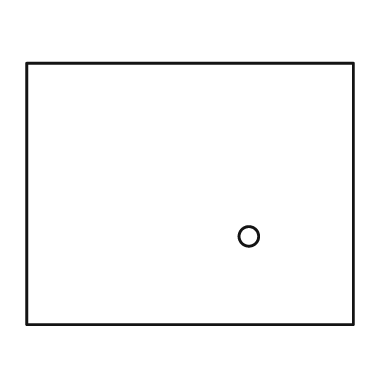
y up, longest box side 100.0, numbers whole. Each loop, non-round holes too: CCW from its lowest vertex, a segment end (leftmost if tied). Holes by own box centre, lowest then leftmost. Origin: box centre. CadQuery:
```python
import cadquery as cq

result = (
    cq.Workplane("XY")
    .moveTo(-50.0, -40.0)
    .lineTo(50.0, -40.0)
    .lineTo(50.0, 40.0)
    .lineTo(-50.0, 40.0)
    .close()
    .moveTo(18.0, -13.0)
    .circle(3.0)
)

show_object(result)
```